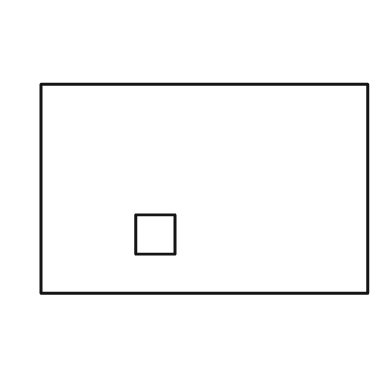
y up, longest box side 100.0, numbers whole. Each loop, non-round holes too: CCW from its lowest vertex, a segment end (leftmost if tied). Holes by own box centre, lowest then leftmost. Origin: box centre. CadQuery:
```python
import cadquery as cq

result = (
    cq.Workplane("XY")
    .moveTo(-50.0, -32.0)
    .lineTo(50.0, -32.0)
    .lineTo(50.0, 32.0)
    .lineTo(-50.0, 32.0)
    .close()
    .moveTo(-21.0, -20.0)
    .lineTo(-9.0, -20.0)
    .lineTo(-9.0, -8.0)
    .lineTo(-21.0, -8.0)
    .close()
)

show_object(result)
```